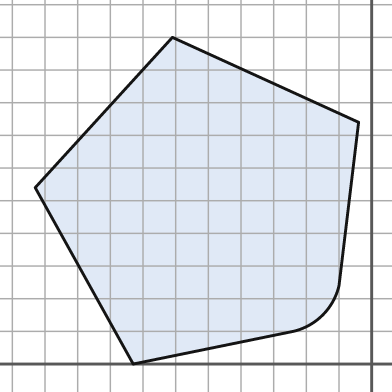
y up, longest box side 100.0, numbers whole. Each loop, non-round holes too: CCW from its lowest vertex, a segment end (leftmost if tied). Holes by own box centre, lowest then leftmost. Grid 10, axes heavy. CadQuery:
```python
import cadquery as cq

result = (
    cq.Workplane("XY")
    .moveTo(-73.0, 0.0)
    .lineTo(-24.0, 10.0)
    .threePointArc((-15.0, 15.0), (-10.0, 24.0))
    .lineTo(-4.0, 74.0)
    .lineTo(-61.0, 100.0)
    .lineTo(-103.0, 54.0)
    .close()
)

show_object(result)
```